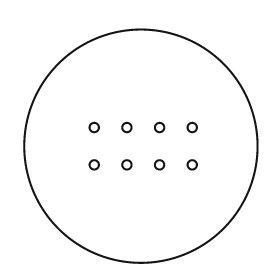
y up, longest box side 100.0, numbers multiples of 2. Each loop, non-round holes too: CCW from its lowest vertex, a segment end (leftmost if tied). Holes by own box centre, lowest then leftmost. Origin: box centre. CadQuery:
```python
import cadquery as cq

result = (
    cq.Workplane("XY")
    .moveTo(0.0, 0.0)
    .circle(50.0)
    .moveTo(-20.0, -8.0)
    .circle(2.0)
    .moveTo(-6.0, -8.0)
    .circle(2.0)
    .moveTo(8.0, -8.0)
    .circle(2.0)
    .moveTo(22.0, -8.0)
    .circle(2.0)
    .moveTo(-20.0, 8.0)
    .circle(2.0)
    .moveTo(-6.0, 8.0)
    .circle(2.0)
    .moveTo(8.0, 8.0)
    .circle(2.0)
    .moveTo(22.0, 8.0)
    .circle(2.0)
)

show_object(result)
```